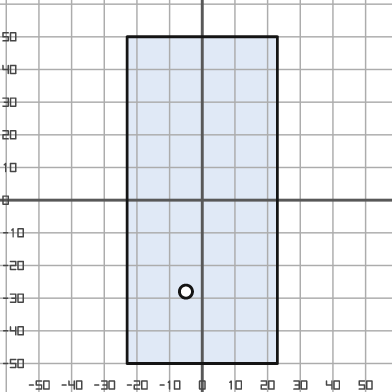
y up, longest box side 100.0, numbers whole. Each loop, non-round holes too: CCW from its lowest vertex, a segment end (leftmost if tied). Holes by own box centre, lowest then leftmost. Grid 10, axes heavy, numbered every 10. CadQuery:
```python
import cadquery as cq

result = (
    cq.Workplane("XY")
    .moveTo(-23.0, -50.0)
    .lineTo(23.0, -50.0)
    .lineTo(23.0, 50.0)
    .lineTo(-23.0, 50.0)
    .close()
    .moveTo(-5.0, -28.0)
    .circle(2.0)
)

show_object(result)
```